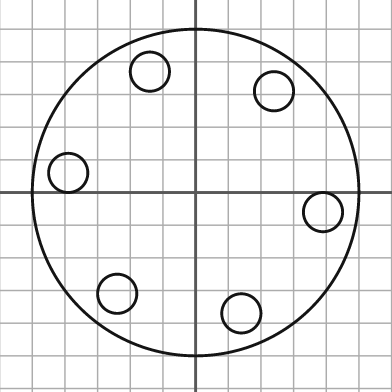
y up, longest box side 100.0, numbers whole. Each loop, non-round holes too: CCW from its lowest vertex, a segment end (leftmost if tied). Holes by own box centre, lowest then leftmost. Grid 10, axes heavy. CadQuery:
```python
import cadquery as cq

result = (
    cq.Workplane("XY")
    .moveTo(0.0, 0.0)
    .circle(50.0)
    .moveTo(14.0, -37.0)
    .circle(6.0)
    .moveTo(-24.0, -31.0)
    .circle(6.0)
    .moveTo(39.0, -6.0)
    .circle(6.0)
    .moveTo(-39.0, 6.0)
    .circle(6.0)
    .moveTo(24.0, 31.0)
    .circle(6.0)
    .moveTo(-14.0, 37.0)
    .circle(6.0)
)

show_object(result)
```